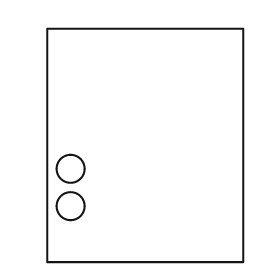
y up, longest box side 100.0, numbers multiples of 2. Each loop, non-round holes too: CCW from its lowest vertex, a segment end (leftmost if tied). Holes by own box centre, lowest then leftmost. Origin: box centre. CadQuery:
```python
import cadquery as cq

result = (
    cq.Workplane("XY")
    .moveTo(-42.0, -50.0)
    .lineTo(42.0, -50.0)
    .lineTo(42.0, 50.0)
    .lineTo(-42.0, 50.0)
    .close()
    .moveTo(-32.0, -26.0)
    .circle(6.0)
    .moveTo(-32.0, -10.0)
    .circle(6.0)
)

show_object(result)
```